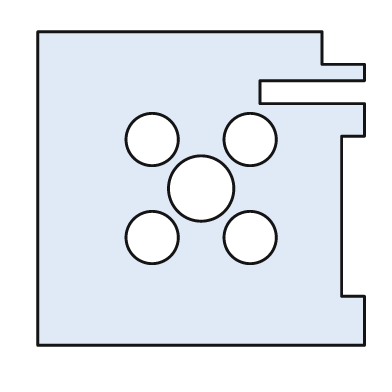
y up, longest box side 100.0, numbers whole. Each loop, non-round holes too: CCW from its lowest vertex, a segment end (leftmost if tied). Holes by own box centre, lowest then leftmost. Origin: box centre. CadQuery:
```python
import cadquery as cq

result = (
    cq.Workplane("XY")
    .moveTo(-50.0, -48.0)
    .lineTo(50.0, -48.0)
    .lineTo(50.0, -33.0)
    .lineTo(43.0, -33.0)
    .lineTo(43.0, 16.0)
    .lineTo(50.0, 16.0)
    .lineTo(50.0, 26.0)
    .lineTo(18.0, 26.0)
    .lineTo(18.0, 33.0)
    .lineTo(50.0, 33.0)
    .lineTo(50.0, 38.0)
    .lineTo(37.0, 38.0)
    .lineTo(37.0, 48.0)
    .lineTo(-50.0, 48.0)
    .close()
    .moveTo(-15.0, -15.0)
    .circle(8.0)
    .moveTo(15.0, -15.0)
    .circle(8.0)
    .moveTo(0.0, 0.0)
    .circle(10.0)
    .moveTo(-15.0, 15.0)
    .circle(8.0)
    .moveTo(15.0, 15.0)
    .circle(8.0)
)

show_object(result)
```